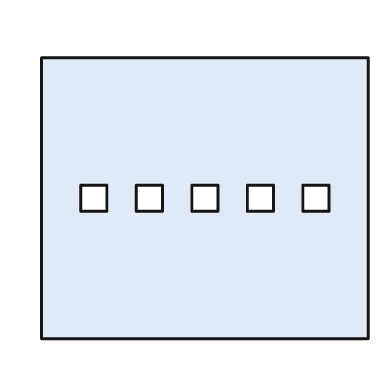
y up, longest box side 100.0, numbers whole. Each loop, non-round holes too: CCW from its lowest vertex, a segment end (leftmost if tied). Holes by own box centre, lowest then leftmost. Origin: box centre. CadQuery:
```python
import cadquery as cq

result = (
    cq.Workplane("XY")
    .moveTo(-50.0, -43.0)
    .lineTo(50.0, -43.0)
    .lineTo(50.0, 43.0)
    .lineTo(-50.0, 43.0)
    .close()
    .moveTo(-38.0, -4.0)
    .lineTo(-30.0, -4.0)
    .lineTo(-30.0, 4.0)
    .lineTo(-38.0, 4.0)
    .close()
    .moveTo(-21.0, -4.0)
    .lineTo(-13.0, -4.0)
    .lineTo(-13.0, 4.0)
    .lineTo(-21.0, 4.0)
    .close()
    .moveTo(-4.0, -4.0)
    .lineTo(4.0, -4.0)
    .lineTo(4.0, 4.0)
    .lineTo(-4.0, 4.0)
    .close()
    .moveTo(13.0, -4.0)
    .lineTo(21.0, -4.0)
    .lineTo(21.0, 4.0)
    .lineTo(13.0, 4.0)
    .close()
    .moveTo(30.0, -4.0)
    .lineTo(38.0, -4.0)
    .lineTo(38.0, 4.0)
    .lineTo(30.0, 4.0)
    .close()
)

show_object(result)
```